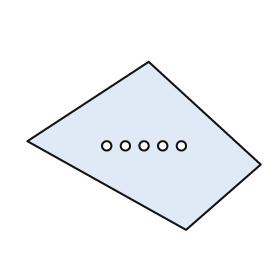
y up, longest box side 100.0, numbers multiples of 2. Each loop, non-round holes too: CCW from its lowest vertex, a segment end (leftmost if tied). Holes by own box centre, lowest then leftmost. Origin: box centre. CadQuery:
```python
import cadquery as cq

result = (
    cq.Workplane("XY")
    .moveTo(18.0, -36.0)
    .lineTo(50.0, -8.0)
    .lineTo(2.0, 36.0)
    .lineTo(-50.0, 2.0)
    .close()
    .moveTo(-16.0, 0.0)
    .circle(2.0)
    .moveTo(-8.0, 0.0)
    .circle(2.0)
    .moveTo(0.0, 0.0)
    .circle(2.0)
    .moveTo(8.0, 0.0)
    .circle(2.0)
    .moveTo(16.0, 0.0)
    .circle(2.0)
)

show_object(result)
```